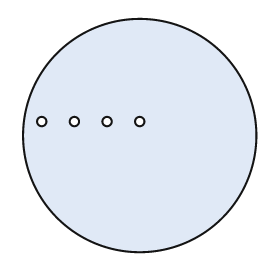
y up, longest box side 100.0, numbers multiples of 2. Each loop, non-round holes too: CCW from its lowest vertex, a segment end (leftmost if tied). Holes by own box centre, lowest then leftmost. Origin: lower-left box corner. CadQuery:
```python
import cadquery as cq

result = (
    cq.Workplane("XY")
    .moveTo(50.0, 50.0)
    .circle(50.0)
    .moveTo(8.0, 56.0)
    .circle(2.0)
    .moveTo(22.0, 56.0)
    .circle(2.0)
    .moveTo(36.0, 56.0)
    .circle(2.0)
    .moveTo(50.0, 56.0)
    .circle(2.0)
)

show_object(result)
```